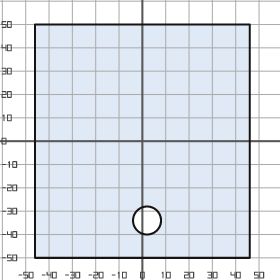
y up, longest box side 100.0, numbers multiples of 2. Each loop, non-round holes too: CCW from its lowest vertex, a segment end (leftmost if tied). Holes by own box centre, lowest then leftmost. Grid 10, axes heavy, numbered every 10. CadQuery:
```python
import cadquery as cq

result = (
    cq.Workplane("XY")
    .moveTo(-46.0, -50.0)
    .lineTo(46.0, -50.0)
    .lineTo(46.0, 50.0)
    .lineTo(-46.0, 50.0)
    .close()
    .moveTo(2.0, -34.0)
    .circle(6.0)
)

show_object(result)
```